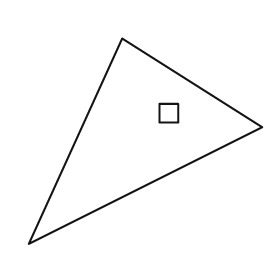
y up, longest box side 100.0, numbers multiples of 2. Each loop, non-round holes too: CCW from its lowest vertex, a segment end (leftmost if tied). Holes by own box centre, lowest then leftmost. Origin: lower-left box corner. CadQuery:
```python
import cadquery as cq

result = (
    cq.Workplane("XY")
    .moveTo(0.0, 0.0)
    .lineTo(100.0, 50.0)
    .lineTo(40.0, 88.0)
    .close()
    .moveTo(56.0, 52.0)
    .lineTo(64.0, 52.0)
    .lineTo(64.0, 60.0)
    .lineTo(56.0, 60.0)
    .close()
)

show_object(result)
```